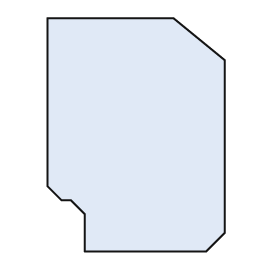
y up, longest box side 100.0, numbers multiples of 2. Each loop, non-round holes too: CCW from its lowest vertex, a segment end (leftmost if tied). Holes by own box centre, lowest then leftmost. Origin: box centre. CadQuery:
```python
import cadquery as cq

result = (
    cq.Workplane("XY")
    .moveTo(-22.0, -50.0)
    .lineTo(30.0, -50.0)
    .lineTo(38.0, -42.0)
    .lineTo(38.0, 32.0)
    .lineTo(16.0, 50.0)
    .lineTo(-38.0, 50.0)
    .lineTo(-38.0, -22.0)
    .lineTo(-32.0, -28.0)
    .lineTo(-28.0, -28.0)
    .lineTo(-22.0, -34.0)
    .close()
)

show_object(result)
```